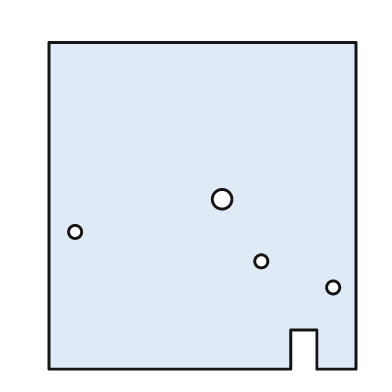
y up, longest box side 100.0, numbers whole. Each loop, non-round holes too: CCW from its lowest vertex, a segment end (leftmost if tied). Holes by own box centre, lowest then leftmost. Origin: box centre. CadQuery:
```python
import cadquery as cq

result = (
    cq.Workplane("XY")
    .moveTo(-47.0, -50.0)
    .lineTo(27.0, -50.0)
    .lineTo(27.0, -38.0)
    .lineTo(35.0, -38.0)
    .lineTo(35.0, -50.0)
    .lineTo(47.0, -50.0)
    .lineTo(47.0, 50.0)
    .lineTo(-47.0, 50.0)
    .close()
    .moveTo(40.0, -25.0)
    .circle(2.0)
    .moveTo(18.0, -17.0)
    .circle(2.0)
    .moveTo(-39.0, -8.0)
    .circle(2.0)
    .moveTo(6.0, 2.0)
    .circle(3.0)
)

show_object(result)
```